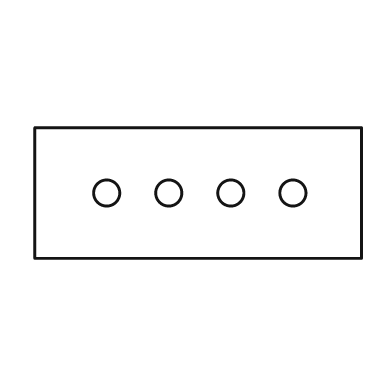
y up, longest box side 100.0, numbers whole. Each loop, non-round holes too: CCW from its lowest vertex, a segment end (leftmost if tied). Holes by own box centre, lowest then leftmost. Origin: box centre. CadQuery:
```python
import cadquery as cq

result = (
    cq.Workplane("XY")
    .moveTo(-50.0, -20.0)
    .lineTo(50.0, -20.0)
    .lineTo(50.0, 20.0)
    .lineTo(-50.0, 20.0)
    .close()
    .moveTo(-28.0, 0.0)
    .circle(4.0)
    .moveTo(-9.0, 0.0)
    .circle(4.0)
    .moveTo(10.0, 0.0)
    .circle(4.0)
    .moveTo(29.0, 0.0)
    .circle(4.0)
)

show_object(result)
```